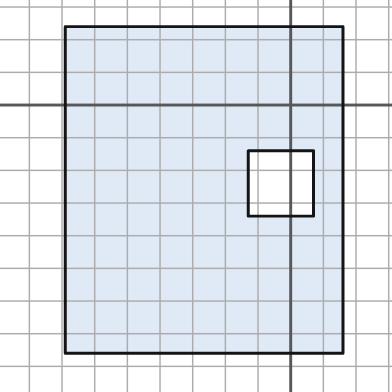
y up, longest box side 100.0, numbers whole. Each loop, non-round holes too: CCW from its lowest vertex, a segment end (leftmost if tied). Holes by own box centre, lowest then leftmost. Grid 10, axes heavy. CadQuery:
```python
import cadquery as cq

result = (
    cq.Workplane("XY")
    .moveTo(-69.0, -76.0)
    .lineTo(16.0, -76.0)
    .lineTo(16.0, 24.0)
    .lineTo(-69.0, 24.0)
    .close()
    .moveTo(-13.0, -34.0)
    .lineTo(7.0, -34.0)
    .lineTo(7.0, -14.0)
    .lineTo(-13.0, -14.0)
    .close()
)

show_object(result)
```